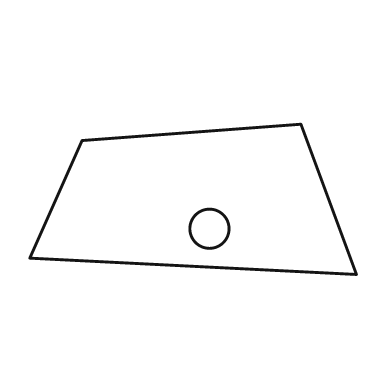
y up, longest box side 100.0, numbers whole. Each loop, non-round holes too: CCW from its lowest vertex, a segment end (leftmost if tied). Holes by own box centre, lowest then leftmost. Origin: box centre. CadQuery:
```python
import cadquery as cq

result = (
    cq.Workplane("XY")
    .moveTo(50.0, -23.0)
    .lineTo(33.0, 23.0)
    .lineTo(-34.0, 18.0)
    .lineTo(-50.0, -18.0)
    .close()
    .moveTo(5.0, -9.0)
    .circle(6.0)
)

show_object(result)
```